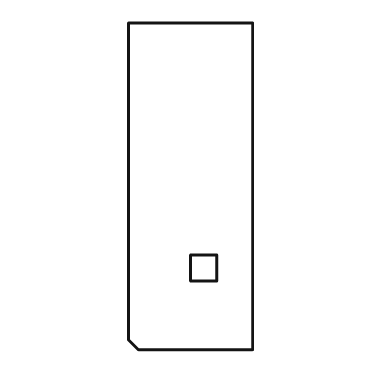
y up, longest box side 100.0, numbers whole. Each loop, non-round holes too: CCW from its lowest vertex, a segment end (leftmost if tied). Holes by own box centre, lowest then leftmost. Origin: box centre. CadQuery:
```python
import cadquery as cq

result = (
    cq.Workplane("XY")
    .moveTo(-16.0, -50.0)
    .lineTo(19.0, -50.0)
    .lineTo(19.0, 50.0)
    .lineTo(-19.0, 50.0)
    .lineTo(-19.0, -47.0)
    .close()
    .moveTo(0.0, -29.0)
    .lineTo(8.0, -29.0)
    .lineTo(8.0, -21.0)
    .lineTo(0.0, -21.0)
    .close()
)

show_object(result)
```